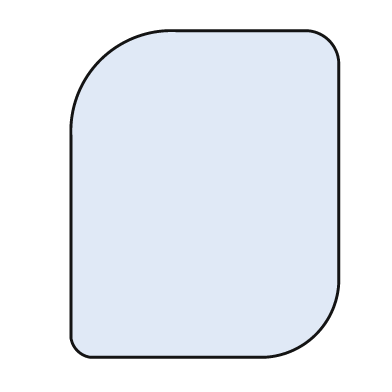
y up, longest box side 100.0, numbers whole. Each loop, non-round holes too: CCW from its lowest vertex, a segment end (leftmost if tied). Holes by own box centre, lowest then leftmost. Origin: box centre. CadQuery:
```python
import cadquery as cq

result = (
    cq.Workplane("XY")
    .moveTo(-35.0, -50.0)
    .lineTo(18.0, -50.0)
    .threePointArc((34.0, -43.0), (41.0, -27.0))
    .lineTo(41.0, 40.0)
    .threePointArc((38.0, 47.0), (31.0, 50.0))
    .lineTo(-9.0, 50.0)
    .threePointArc((-32.0, 41.0), (-41.0, 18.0))
    .lineTo(-41.0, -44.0)
    .threePointArc((-39.0, -48.0), (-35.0, -50.0))
    .close()
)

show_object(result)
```